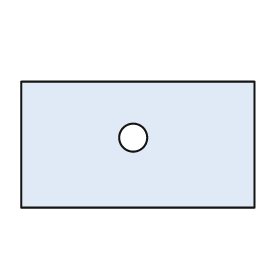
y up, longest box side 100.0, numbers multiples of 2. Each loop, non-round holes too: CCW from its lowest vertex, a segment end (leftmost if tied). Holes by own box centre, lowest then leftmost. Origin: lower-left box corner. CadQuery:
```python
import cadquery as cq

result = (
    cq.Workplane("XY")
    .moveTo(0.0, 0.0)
    .lineTo(100.0, 0.0)
    .lineTo(100.0, 54.0)
    .lineTo(0.0, 54.0)
    .close()
    .moveTo(48.0, 30.0)
    .circle(6.0)
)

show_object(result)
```